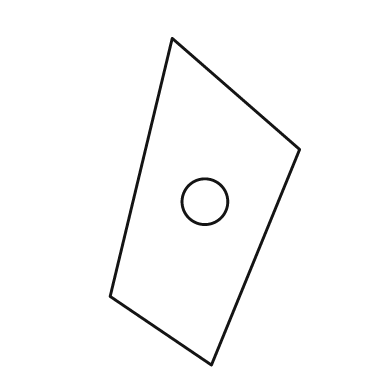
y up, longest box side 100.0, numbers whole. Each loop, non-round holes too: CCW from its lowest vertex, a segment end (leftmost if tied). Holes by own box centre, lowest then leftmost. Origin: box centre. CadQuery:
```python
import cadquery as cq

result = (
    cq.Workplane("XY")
    .moveTo(2.0, -50.0)
    .lineTo(29.0, 16.0)
    .lineTo(-10.0, 50.0)
    .lineTo(-29.0, -29.0)
    .close()
    .moveTo(0.0, 0.0)
    .circle(7.0)
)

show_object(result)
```